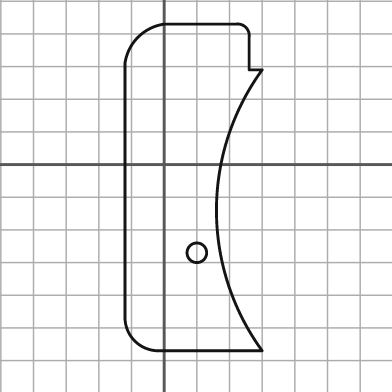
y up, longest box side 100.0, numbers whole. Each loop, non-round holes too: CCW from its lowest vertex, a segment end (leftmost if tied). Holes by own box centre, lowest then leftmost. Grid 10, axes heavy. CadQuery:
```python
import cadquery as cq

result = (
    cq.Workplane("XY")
    .moveTo(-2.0, -57.0)
    .lineTo(30.0, -57.0)
    .threePointArc((16.0, -14.0), (30.0, 29.0))
    .lineTo(26.0, 29.0)
    .lineTo(26.0, 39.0)
    .threePointArc((25.0, 42.0), (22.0, 43.0))
    .lineTo(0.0, 43.0)
    .threePointArc((-8.0, 39.0), (-12.0, 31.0))
    .lineTo(-12.0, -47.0)
    .threePointArc((-9.0, -54.0), (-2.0, -57.0))
    .close()
    .moveTo(10.0, -27.0)
    .circle(3.0)
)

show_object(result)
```